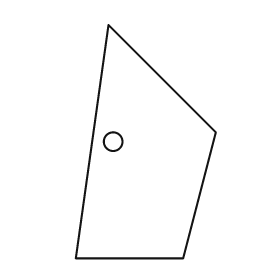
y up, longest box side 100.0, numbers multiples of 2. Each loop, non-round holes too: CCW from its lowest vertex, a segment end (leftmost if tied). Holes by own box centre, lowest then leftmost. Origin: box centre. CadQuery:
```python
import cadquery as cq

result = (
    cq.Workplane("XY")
    .moveTo(-30.0, -50.0)
    .lineTo(16.0, -50.0)
    .lineTo(30.0, 4.0)
    .lineTo(-16.0, 50.0)
    .close()
    .moveTo(-14.0, 0.0)
    .circle(4.0)
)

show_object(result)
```